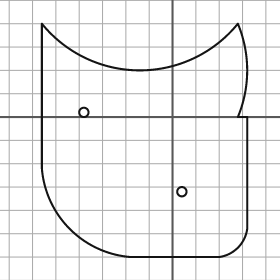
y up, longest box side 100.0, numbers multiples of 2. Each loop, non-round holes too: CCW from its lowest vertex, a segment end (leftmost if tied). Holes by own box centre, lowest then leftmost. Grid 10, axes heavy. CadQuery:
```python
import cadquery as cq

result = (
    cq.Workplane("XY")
    .moveTo(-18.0, -60.0)
    .lineTo(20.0, -60.0)
    .threePointArc((28.0, -56.0), (32.0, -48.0))
    .lineTo(32.0, 0.0)
    .lineTo(28.0, 0.0)
    .threePointArc((32.0, 20.0), (28.0, 40.0))
    .threePointArc((-14.0, 20.0), (-56.0, 40.0))
    .lineTo(-56.0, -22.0)
    .threePointArc((-44.0, -48.0), (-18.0, -60.0))
    .close()
    .moveTo(4.0, -32.0)
    .circle(2.0)
    .moveTo(-38.0, 2.0)
    .circle(2.0)
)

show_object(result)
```